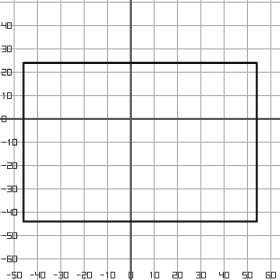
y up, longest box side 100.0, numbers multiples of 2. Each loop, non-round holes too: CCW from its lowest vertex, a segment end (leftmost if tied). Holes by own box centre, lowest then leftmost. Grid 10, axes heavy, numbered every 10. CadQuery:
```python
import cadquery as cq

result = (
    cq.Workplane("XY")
    .moveTo(-46.0, -44.0)
    .lineTo(54.0, -44.0)
    .lineTo(54.0, 24.0)
    .lineTo(-46.0, 24.0)
    .close()
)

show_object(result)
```